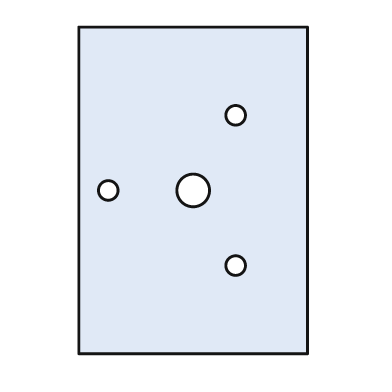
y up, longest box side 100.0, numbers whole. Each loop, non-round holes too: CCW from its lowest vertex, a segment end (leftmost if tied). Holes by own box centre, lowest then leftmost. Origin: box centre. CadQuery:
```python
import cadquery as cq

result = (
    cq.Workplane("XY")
    .moveTo(-35.0, -50.0)
    .lineTo(35.0, -50.0)
    .lineTo(35.0, 50.0)
    .lineTo(-35.0, 50.0)
    .close()
    .moveTo(13.0, -23.0)
    .circle(3.0)
    .moveTo(-26.0, 0.0)
    .circle(3.0)
    .moveTo(0.0, 0.0)
    .circle(5.0)
    .moveTo(13.0, 23.0)
    .circle(3.0)
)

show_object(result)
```